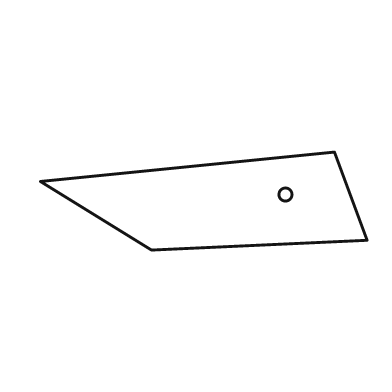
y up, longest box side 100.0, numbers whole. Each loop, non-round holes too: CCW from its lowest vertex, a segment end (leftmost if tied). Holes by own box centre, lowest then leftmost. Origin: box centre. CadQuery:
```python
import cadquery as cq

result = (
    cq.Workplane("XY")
    .moveTo(-16.0, -15.0)
    .lineTo(50.0, -12.0)
    .lineTo(40.0, 15.0)
    .lineTo(-50.0, 6.0)
    .close()
    .moveTo(25.0, 2.0)
    .circle(2.0)
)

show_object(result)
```